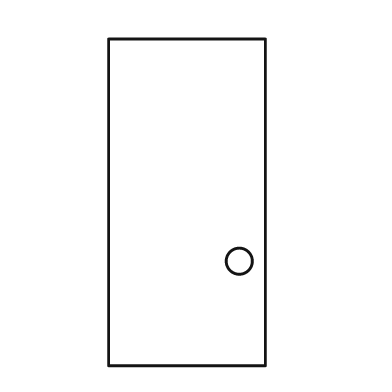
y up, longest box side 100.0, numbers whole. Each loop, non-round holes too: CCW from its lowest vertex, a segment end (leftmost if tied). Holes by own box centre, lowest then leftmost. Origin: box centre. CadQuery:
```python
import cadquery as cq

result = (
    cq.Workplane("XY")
    .moveTo(-24.0, -50.0)
    .lineTo(24.0, -50.0)
    .lineTo(24.0, 50.0)
    .lineTo(-24.0, 50.0)
    .close()
    .moveTo(16.0, -18.0)
    .circle(4.0)
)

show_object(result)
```